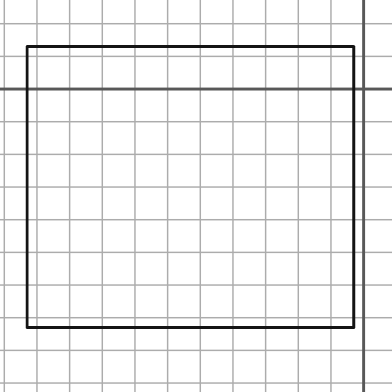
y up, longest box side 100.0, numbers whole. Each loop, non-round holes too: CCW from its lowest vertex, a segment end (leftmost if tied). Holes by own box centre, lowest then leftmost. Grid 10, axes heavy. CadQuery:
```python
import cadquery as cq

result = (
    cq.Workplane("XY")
    .moveTo(-103.0, -73.0)
    .lineTo(-3.0, -73.0)
    .lineTo(-3.0, 13.0)
    .lineTo(-103.0, 13.0)
    .close()
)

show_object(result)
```